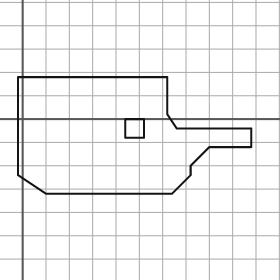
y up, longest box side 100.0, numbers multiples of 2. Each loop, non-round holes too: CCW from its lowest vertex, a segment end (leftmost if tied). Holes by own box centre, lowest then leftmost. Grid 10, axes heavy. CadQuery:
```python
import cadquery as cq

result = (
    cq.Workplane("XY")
    .moveTo(10.0, -32.0)
    .lineTo(64.0, -32.0)
    .lineTo(72.0, -24.0)
    .lineTo(72.0, -20.0)
    .lineTo(80.0, -12.0)
    .lineTo(98.0, -12.0)
    .lineTo(98.0, -4.0)
    .lineTo(66.0, -4.0)
    .lineTo(62.0, 2.0)
    .lineTo(62.0, 18.0)
    .lineTo(-2.0, 18.0)
    .lineTo(-2.0, -24.0)
    .close()
    .moveTo(44.0, -8.0)
    .lineTo(52.0, -8.0)
    .lineTo(52.0, 0.0)
    .lineTo(44.0, 0.0)
    .close()
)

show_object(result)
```